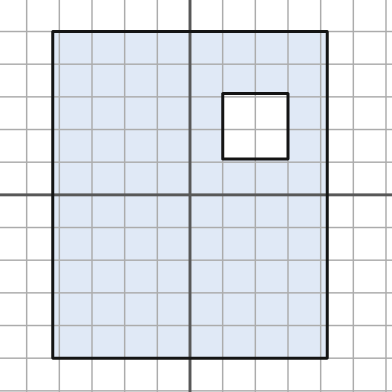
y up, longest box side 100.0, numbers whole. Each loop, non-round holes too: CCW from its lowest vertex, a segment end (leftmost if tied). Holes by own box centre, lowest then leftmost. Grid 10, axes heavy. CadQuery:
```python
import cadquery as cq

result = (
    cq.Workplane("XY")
    .moveTo(-42.0, -50.0)
    .lineTo(42.0, -50.0)
    .lineTo(42.0, 50.0)
    .lineTo(-42.0, 50.0)
    .close()
    .moveTo(10.0, 11.0)
    .lineTo(30.0, 11.0)
    .lineTo(30.0, 31.0)
    .lineTo(10.0, 31.0)
    .close()
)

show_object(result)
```